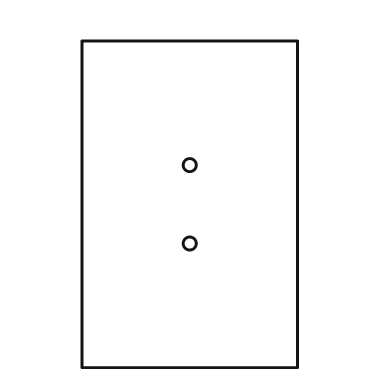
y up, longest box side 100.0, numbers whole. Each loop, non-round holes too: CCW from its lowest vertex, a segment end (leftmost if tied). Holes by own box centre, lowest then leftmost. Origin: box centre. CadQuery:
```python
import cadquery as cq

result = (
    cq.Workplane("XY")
    .moveTo(-33.0, -50.0)
    .lineTo(33.0, -50.0)
    .lineTo(33.0, 50.0)
    .lineTo(-33.0, 50.0)
    .close()
    .moveTo(0.0, -12.0)
    .circle(2.0)
    .moveTo(0.0, 12.0)
    .circle(2.0)
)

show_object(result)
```